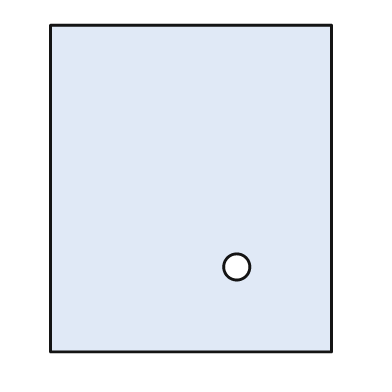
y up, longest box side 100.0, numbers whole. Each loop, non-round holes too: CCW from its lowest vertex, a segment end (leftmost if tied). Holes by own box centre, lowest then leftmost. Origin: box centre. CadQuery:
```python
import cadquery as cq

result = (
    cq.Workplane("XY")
    .moveTo(-43.0, -50.0)
    .lineTo(43.0, -50.0)
    .lineTo(43.0, 50.0)
    .lineTo(-43.0, 50.0)
    .close()
    .moveTo(14.0, -24.0)
    .circle(4.0)
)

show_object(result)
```